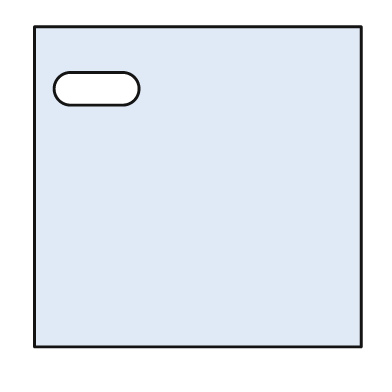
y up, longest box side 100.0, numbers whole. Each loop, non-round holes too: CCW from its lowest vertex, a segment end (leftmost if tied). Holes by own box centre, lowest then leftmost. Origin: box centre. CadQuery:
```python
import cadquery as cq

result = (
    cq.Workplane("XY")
    .moveTo(-50.0, -49.0)
    .lineTo(50.0, -49.0)
    .lineTo(50.0, 49.0)
    .lineTo(-50.0, 49.0)
    .close()
    .moveTo(-39.0, 25.0)
    .lineTo(-23.0, 25.0)
    .threePointArc((-18.0, 30.0), (-23.0, 35.0))
    .lineTo(-39.0, 35.0)
    .threePointArc((-44.0, 30.0), (-39.0, 25.0))
    .close()
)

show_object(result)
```